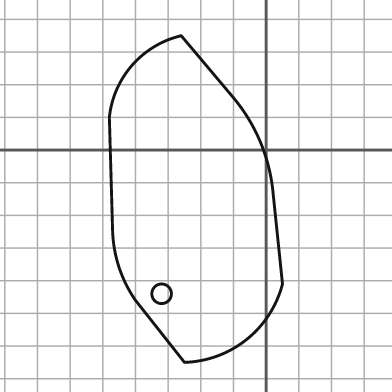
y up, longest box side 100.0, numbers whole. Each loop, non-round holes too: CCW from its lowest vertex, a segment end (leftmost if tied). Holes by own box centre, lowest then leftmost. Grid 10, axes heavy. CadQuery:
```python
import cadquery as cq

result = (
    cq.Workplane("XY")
    .moveTo(-25.0, -65.0)
    .threePointArc((-6.0, -58.0), (5.0, -41.0))
    .lineTo(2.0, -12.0)
    .threePointArc((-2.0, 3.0), (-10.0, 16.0))
    .lineTo(-26.0, 35.0)
    .threePointArc((-41.0, 26.0), (-48.0, 10.0))
    .lineTo(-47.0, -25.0)
    .threePointArc((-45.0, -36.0), (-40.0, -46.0))
    .close()
    .moveTo(-32.0, -44.0)
    .circle(3.0)
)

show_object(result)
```